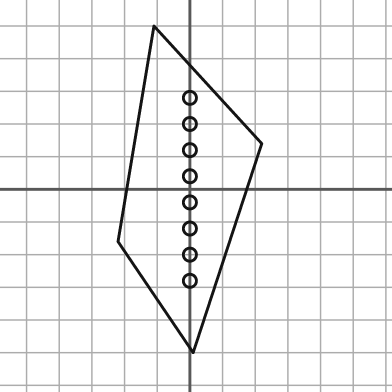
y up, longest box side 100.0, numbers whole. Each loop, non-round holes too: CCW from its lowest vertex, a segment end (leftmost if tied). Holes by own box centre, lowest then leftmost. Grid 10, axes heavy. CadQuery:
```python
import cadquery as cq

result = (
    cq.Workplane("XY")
    .moveTo(1.0, -50.0)
    .lineTo(22.0, 14.0)
    .lineTo(-11.0, 50.0)
    .lineTo(-22.0, -16.0)
    .close()
    .moveTo(0.0, -28.0)
    .circle(2.0)
    .moveTo(0.0, -20.0)
    .circle(2.0)
    .moveTo(0.0, -12.0)
    .circle(2.0)
    .moveTo(0.0, -4.0)
    .circle(2.0)
    .moveTo(0.0, 4.0)
    .circle(2.0)
    .moveTo(0.0, 12.0)
    .circle(2.0)
    .moveTo(0.0, 20.0)
    .circle(2.0)
    .moveTo(0.0, 28.0)
    .circle(2.0)
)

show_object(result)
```